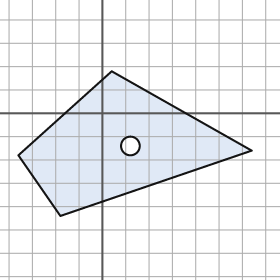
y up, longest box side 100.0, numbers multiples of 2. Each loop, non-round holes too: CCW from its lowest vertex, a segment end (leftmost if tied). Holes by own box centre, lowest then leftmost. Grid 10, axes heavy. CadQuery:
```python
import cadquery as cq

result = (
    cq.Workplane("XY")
    .moveTo(-18.0, -44.0)
    .lineTo(64.0, -16.0)
    .lineTo(4.0, 18.0)
    .lineTo(-36.0, -18.0)
    .close()
    .moveTo(12.0, -14.0)
    .circle(4.0)
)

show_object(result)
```